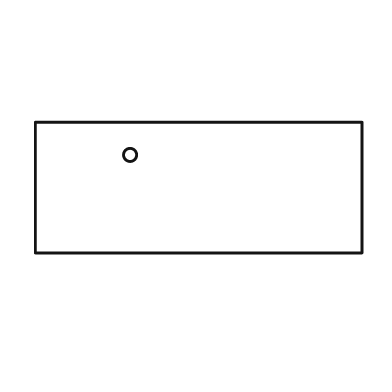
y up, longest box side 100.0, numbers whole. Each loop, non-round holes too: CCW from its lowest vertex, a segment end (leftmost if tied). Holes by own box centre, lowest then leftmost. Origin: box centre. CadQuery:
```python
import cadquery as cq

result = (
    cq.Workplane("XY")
    .moveTo(-50.0, -20.0)
    .lineTo(50.0, -20.0)
    .lineTo(50.0, 20.0)
    .lineTo(-50.0, 20.0)
    .close()
    .moveTo(-21.0, 10.0)
    .circle(2.0)
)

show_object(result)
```